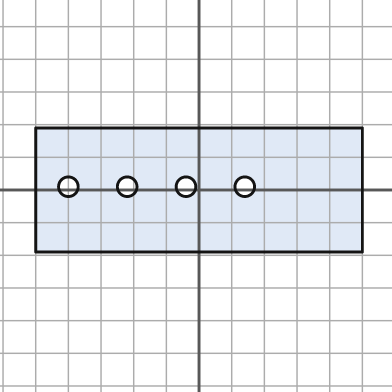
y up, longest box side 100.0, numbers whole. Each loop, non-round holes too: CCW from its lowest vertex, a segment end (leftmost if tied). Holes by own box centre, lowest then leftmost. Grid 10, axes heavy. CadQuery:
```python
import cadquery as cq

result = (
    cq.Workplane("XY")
    .moveTo(-50.0, -19.0)
    .lineTo(50.0, -19.0)
    .lineTo(50.0, 19.0)
    .lineTo(-50.0, 19.0)
    .close()
    .moveTo(-40.0, 1.0)
    .circle(3.0)
    .moveTo(-22.0, 1.0)
    .circle(3.0)
    .moveTo(-4.0, 1.0)
    .circle(3.0)
    .moveTo(14.0, 1.0)
    .circle(3.0)
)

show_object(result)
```